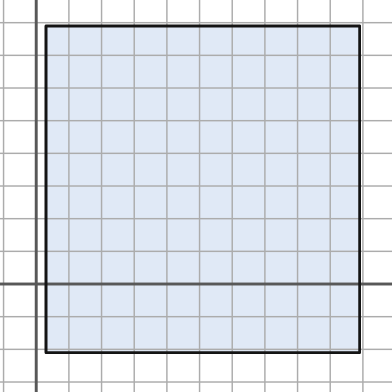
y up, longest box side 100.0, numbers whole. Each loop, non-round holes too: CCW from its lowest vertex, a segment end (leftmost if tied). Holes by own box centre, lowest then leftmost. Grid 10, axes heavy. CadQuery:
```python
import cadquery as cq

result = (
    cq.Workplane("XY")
    .moveTo(3.0, -21.0)
    .lineTo(99.0, -21.0)
    .lineTo(99.0, 79.0)
    .lineTo(3.0, 79.0)
    .close()
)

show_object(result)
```